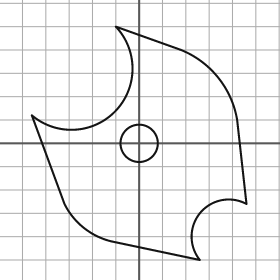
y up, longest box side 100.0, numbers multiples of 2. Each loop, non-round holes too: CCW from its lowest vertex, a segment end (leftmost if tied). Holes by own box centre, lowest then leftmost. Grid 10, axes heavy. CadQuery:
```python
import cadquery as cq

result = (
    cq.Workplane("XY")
    .moveTo(26.0, -50.0)
    .threePointArc((26.0, -30.0), (46.0, -26.0))
    .lineTo(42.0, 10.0)
    .threePointArc((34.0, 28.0), (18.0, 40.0))
    .lineTo(-10.0, 50.0)
    .threePointArc((-10.0, 14.0), (-46.0, 12.0))
    .lineTo(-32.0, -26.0)
    .threePointArc((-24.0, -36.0), (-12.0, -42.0))
    .close()
    .moveTo(0.0, 0.0)
    .circle(8.0)
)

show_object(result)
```